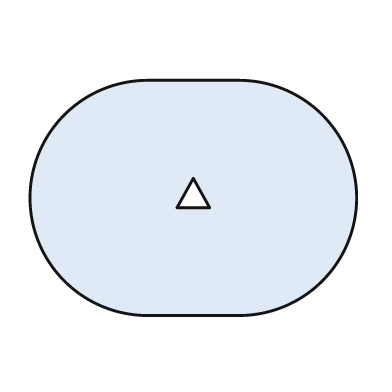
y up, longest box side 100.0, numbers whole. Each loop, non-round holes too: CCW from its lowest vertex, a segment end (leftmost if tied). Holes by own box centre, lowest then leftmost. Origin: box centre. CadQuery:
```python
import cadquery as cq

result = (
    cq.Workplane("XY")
    .moveTo(-14.0, -36.0)
    .lineTo(14.0, -36.0)
    .threePointArc((50.0, 0.0), (14.0, 36.0))
    .lineTo(-14.0, 36.0)
    .threePointArc((-50.0, 0.0), (-14.0, -36.0))
    .close()
    .moveTo(-5.0, -3.0)
    .lineTo(5.0, -3.0)
    .lineTo(0.0, 6.0)
    .close()
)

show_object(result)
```